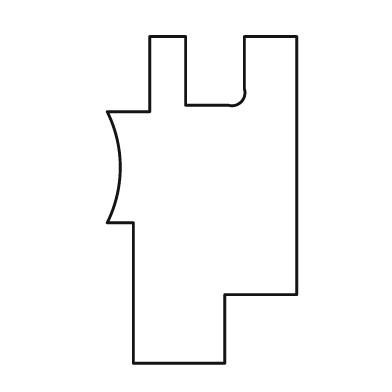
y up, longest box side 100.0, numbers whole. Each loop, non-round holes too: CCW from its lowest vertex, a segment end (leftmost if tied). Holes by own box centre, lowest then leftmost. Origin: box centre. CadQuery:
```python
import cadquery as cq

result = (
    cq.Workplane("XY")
    .moveTo(-21.0, -50.0)
    .lineTo(7.0, -50.0)
    .lineTo(7.0, -29.0)
    .lineTo(29.0, -29.0)
    .lineTo(29.0, 50.0)
    .lineTo(13.0, 50.0)
    .lineTo(13.0, 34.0)
    .threePointArc((12.0, 30.0), (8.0, 29.0))
    .lineTo(-5.0, 29.0)
    .lineTo(-5.0, 50.0)
    .lineTo(-16.0, 50.0)
    .lineTo(-16.0, 27.0)
    .lineTo(-29.0, 27.0)
    .threePointArc((-25.0, 10.0), (-29.0, -7.0))
    .lineTo(-21.0, -7.0)
    .close()
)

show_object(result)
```